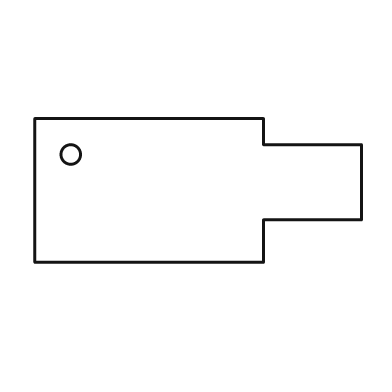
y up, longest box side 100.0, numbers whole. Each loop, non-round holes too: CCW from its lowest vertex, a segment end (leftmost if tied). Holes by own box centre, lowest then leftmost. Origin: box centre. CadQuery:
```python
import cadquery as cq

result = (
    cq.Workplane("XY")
    .moveTo(-50.0, -22.0)
    .lineTo(20.0, -22.0)
    .lineTo(20.0, -9.0)
    .lineTo(50.0, -9.0)
    .lineTo(50.0, 14.0)
    .lineTo(20.0, 14.0)
    .lineTo(20.0, 22.0)
    .lineTo(-50.0, 22.0)
    .close()
    .moveTo(-39.0, 11.0)
    .circle(3.0)
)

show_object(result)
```